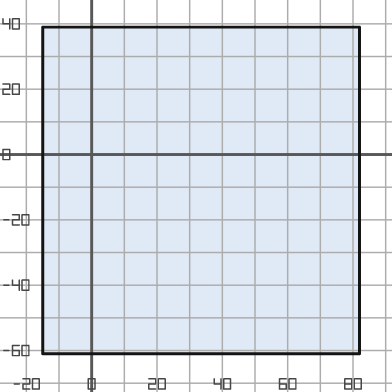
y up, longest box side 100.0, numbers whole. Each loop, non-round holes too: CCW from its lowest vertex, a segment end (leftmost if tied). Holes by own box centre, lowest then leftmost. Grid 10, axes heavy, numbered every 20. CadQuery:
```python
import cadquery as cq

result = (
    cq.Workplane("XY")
    .moveTo(-15.0, -61.0)
    .lineTo(82.0, -61.0)
    .lineTo(82.0, 39.0)
    .lineTo(-15.0, 39.0)
    .close()
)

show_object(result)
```